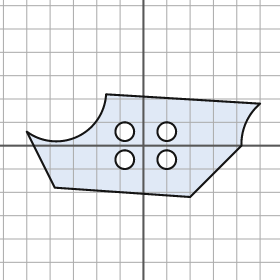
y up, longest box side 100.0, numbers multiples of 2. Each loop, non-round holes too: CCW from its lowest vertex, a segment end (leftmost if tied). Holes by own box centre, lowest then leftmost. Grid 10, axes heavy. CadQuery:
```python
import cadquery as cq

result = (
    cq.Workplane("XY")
    .moveTo(20.0, -22.0)
    .lineTo(42.0, 0.0)
    .threePointArc((44.0, 10.0), (50.0, 18.0))
    .lineTo(-16.0, 22.0)
    .threePointArc((-28.0, 4.0), (-50.0, 6.0))
    .lineTo(-38.0, -18.0)
    .close()
    .moveTo(-8.0, -6.0)
    .circle(4.0)
    .moveTo(10.0, -6.0)
    .circle(4.0)
    .moveTo(-8.0, 6.0)
    .circle(4.0)
    .moveTo(10.0, 6.0)
    .circle(4.0)
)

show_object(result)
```